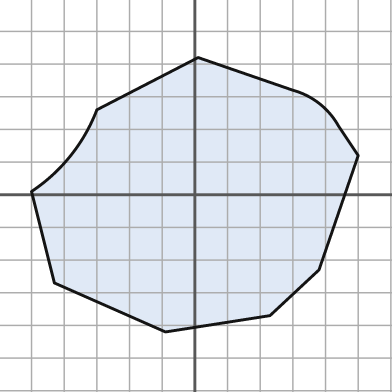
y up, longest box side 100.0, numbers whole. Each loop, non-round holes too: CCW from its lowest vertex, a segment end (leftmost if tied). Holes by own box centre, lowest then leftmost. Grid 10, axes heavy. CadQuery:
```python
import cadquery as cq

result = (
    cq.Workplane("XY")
    .moveTo(-9.0, -42.0)
    .lineTo(23.0, -37.0)
    .lineTo(38.0, -23.0)
    .lineTo(50.0, 12.0)
    .lineTo(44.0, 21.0)
    .threePointArc((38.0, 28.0), (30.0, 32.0))
    .lineTo(1.0, 42.0)
    .lineTo(-30.0, 26.0)
    .threePointArc((-38.0, 12.0), (-50.0, 1.0))
    .lineTo(-43.0, -27.0)
    .close()
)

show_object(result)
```